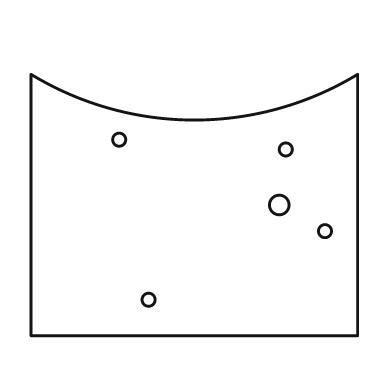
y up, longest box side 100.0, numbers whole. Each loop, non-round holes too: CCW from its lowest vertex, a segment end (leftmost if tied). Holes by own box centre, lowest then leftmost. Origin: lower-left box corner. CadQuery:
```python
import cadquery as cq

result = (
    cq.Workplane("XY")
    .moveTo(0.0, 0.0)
    .lineTo(100.0, 0.0)
    .lineTo(100.0, 80.0)
    .threePointArc((50.0, 66.0), (0.0, 80.0))
    .close()
    .moveTo(36.0, 11.0)
    .circle(2.0)
    .moveTo(90.0, 32.0)
    .circle(2.0)
    .moveTo(76.0, 40.0)
    .circle(3.0)
    .moveTo(78.0, 57.0)
    .circle(2.0)
    .moveTo(27.0, 60.0)
    .circle(2.0)
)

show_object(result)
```